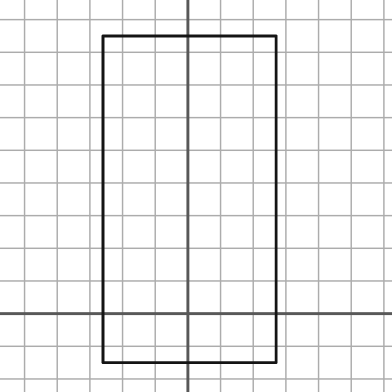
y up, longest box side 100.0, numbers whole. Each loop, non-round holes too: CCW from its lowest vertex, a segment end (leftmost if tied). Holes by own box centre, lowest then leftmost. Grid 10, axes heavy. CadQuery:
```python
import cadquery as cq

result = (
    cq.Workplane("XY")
    .moveTo(-26.0, -15.0)
    .lineTo(27.0, -15.0)
    .lineTo(27.0, 85.0)
    .lineTo(-26.0, 85.0)
    .close()
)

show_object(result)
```